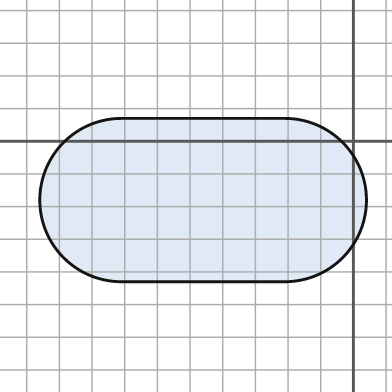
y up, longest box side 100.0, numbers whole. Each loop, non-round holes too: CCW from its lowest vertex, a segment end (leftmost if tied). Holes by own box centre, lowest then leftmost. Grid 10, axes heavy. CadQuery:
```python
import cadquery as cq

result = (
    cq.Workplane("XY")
    .moveTo(-71.0, -43.0)
    .lineTo(-21.0, -43.0)
    .threePointArc((4.0, -18.0), (-21.0, 7.0))
    .lineTo(-71.0, 7.0)
    .threePointArc((-96.0, -18.0), (-71.0, -43.0))
    .close()
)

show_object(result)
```